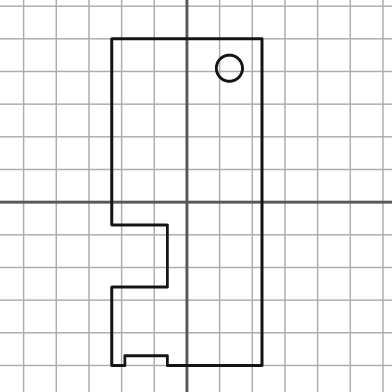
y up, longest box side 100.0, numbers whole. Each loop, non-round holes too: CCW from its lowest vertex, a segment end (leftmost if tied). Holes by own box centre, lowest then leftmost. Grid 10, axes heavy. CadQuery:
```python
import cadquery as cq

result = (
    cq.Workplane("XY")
    .moveTo(-23.0, -50.0)
    .lineTo(-19.0, -50.0)
    .lineTo(-19.0, -47.0)
    .lineTo(-6.0, -47.0)
    .lineTo(-6.0, -50.0)
    .lineTo(23.0, -50.0)
    .lineTo(23.0, 50.0)
    .lineTo(-23.0, 50.0)
    .lineTo(-23.0, -7.0)
    .lineTo(-6.0, -7.0)
    .lineTo(-6.0, -26.0)
    .lineTo(-23.0, -26.0)
    .close()
    .moveTo(13.0, 41.0)
    .circle(4.0)
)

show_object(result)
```